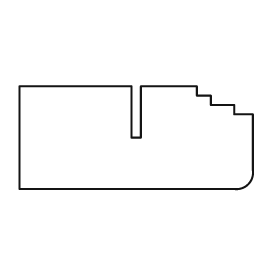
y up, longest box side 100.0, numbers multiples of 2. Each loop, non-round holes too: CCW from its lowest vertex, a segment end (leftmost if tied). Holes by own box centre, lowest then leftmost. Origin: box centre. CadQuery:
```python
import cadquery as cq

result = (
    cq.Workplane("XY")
    .moveTo(-50.0, -22.0)
    .lineTo(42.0, -22.0)
    .threePointArc((48.0, -20.0), (50.0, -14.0))
    .lineTo(50.0, 10.0)
    .lineTo(42.0, 10.0)
    .lineTo(42.0, 14.0)
    .lineTo(32.0, 14.0)
    .lineTo(32.0, 18.0)
    .lineTo(26.0, 18.0)
    .lineTo(26.0, 22.0)
    .lineTo(2.0, 22.0)
    .lineTo(2.0, 0.0)
    .lineTo(-2.0, 0.0)
    .lineTo(-2.0, 22.0)
    .lineTo(-50.0, 22.0)
    .close()
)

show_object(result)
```